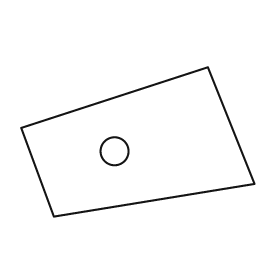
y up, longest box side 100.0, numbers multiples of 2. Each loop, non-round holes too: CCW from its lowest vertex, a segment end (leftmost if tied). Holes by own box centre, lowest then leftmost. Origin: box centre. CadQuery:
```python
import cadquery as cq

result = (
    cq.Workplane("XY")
    .moveTo(-36.0, -32.0)
    .lineTo(50.0, -18.0)
    .lineTo(30.0, 32.0)
    .lineTo(-50.0, 6.0)
    .close()
    .moveTo(-10.0, -4.0)
    .circle(6.0)
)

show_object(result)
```